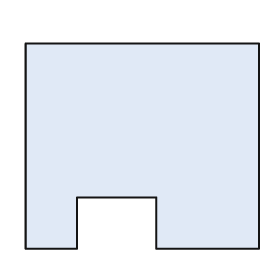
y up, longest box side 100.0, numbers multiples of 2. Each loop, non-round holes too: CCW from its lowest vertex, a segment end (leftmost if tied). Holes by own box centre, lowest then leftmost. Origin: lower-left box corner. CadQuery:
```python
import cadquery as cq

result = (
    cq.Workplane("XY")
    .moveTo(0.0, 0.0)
    .lineTo(22.0, 0.0)
    .lineTo(22.0, 22.0)
    .lineTo(56.0, 22.0)
    .lineTo(56.0, 0.0)
    .lineTo(100.0, 0.0)
    .lineTo(100.0, 88.0)
    .lineTo(0.0, 88.0)
    .close()
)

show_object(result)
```